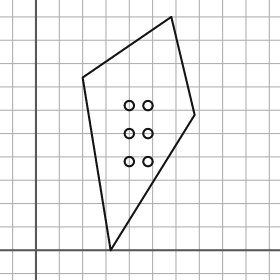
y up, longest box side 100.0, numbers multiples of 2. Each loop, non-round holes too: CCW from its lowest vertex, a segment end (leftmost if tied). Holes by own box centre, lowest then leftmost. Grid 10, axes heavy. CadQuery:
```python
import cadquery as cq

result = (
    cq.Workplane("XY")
    .moveTo(32.0, 0.0)
    .lineTo(68.0, 58.0)
    .lineTo(58.0, 100.0)
    .lineTo(20.0, 74.0)
    .close()
    .moveTo(40.0, 38.0)
    .circle(2.0)
    .moveTo(48.0, 38.0)
    .circle(2.0)
    .moveTo(40.0, 50.0)
    .circle(2.0)
    .moveTo(48.0, 50.0)
    .circle(2.0)
    .moveTo(40.0, 62.0)
    .circle(2.0)
    .moveTo(48.0, 62.0)
    .circle(2.0)
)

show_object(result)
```